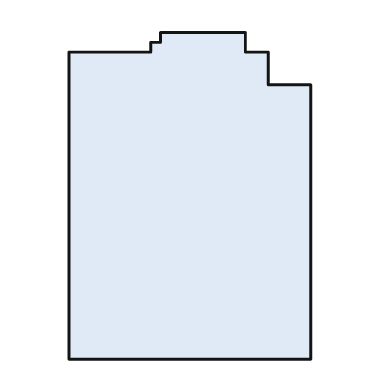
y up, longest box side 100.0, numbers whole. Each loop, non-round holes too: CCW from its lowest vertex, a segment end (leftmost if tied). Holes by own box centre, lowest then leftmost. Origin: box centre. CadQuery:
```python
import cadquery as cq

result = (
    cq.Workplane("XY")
    .moveTo(-37.0, -50.0)
    .lineTo(37.0, -50.0)
    .lineTo(37.0, 34.0)
    .lineTo(24.0, 34.0)
    .lineTo(24.0, 44.0)
    .lineTo(17.0, 44.0)
    .lineTo(17.0, 50.0)
    .lineTo(-9.0, 50.0)
    .lineTo(-9.0, 47.0)
    .lineTo(-12.0, 47.0)
    .lineTo(-12.0, 44.0)
    .lineTo(-37.0, 44.0)
    .close()
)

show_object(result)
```